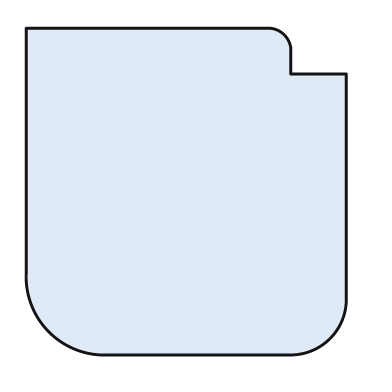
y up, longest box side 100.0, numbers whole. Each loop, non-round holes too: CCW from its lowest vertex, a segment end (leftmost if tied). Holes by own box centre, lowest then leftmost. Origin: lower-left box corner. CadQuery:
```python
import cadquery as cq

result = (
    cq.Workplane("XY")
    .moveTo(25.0, 0.0)
    .lineTo(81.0, 0.0)
    .threePointArc((93.0, 5.0), (98.0, 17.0))
    .lineTo(98.0, 86.0)
    .lineTo(81.0, 86.0)
    .lineTo(81.0, 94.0)
    .threePointArc((79.0, 98.0), (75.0, 100.0))
    .lineTo(0.0, 100.0)
    .lineTo(0.0, 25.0)
    .threePointArc((7.0, 7.0), (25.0, 0.0))
    .close()
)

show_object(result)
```